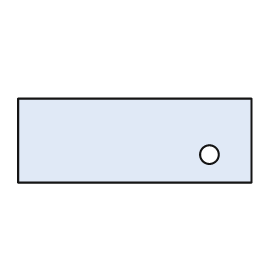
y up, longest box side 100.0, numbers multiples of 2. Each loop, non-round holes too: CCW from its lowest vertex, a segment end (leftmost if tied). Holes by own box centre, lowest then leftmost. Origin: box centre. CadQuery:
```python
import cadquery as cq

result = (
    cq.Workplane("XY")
    .moveTo(-50.0, -18.0)
    .lineTo(50.0, -18.0)
    .lineTo(50.0, 18.0)
    .lineTo(-50.0, 18.0)
    .close()
    .moveTo(32.0, -6.0)
    .circle(4.0)
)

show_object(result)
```